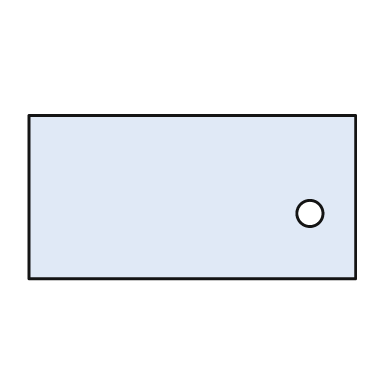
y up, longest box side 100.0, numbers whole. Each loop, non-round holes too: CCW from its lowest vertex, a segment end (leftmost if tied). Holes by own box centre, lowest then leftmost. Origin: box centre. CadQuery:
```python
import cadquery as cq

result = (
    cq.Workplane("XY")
    .moveTo(-50.0, -25.0)
    .lineTo(50.0, -25.0)
    .lineTo(50.0, 25.0)
    .lineTo(-50.0, 25.0)
    .close()
    .moveTo(36.0, -5.0)
    .circle(4.0)
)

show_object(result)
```